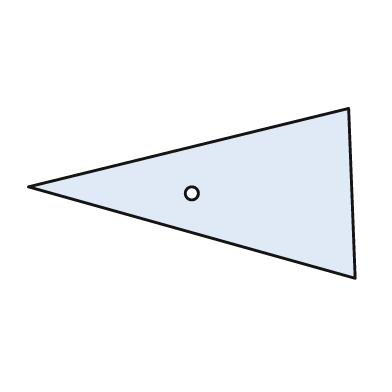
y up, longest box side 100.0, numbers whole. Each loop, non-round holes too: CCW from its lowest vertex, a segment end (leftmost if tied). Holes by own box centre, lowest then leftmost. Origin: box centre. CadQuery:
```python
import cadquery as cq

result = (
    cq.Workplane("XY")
    .moveTo(50.0, -26.0)
    .lineTo(48.0, 26.0)
    .lineTo(-50.0, 2.0)
    .close()
    .moveTo(0.0, 0.0)
    .circle(2.0)
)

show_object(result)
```